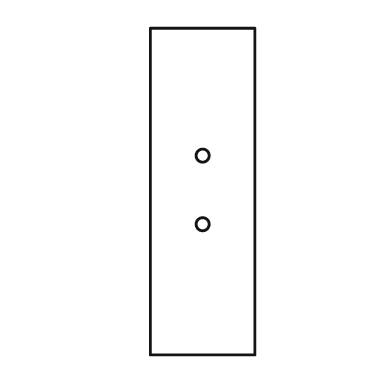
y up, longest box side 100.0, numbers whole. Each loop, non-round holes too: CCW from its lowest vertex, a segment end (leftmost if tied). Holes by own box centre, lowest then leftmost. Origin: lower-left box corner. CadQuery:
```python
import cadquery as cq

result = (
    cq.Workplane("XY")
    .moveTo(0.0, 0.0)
    .lineTo(32.0, 0.0)
    .lineTo(32.0, 100.0)
    .lineTo(0.0, 100.0)
    .close()
    .moveTo(16.0, 40.0)
    .circle(2.0)
    .moveTo(16.0, 61.0)
    .circle(2.0)
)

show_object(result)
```